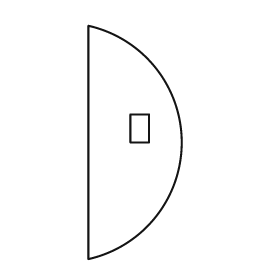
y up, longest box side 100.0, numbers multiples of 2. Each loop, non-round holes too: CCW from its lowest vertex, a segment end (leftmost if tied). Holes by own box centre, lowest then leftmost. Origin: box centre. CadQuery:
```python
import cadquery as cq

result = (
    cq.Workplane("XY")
    .moveTo(-20.0, -50.0)
    .threePointArc((20.0, 0.0), (-20.0, 50.0))
    .close()
    .moveTo(-2.0, 0.0)
    .lineTo(6.0, 0.0)
    .lineTo(6.0, 12.0)
    .lineTo(-2.0, 12.0)
    .close()
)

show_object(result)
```